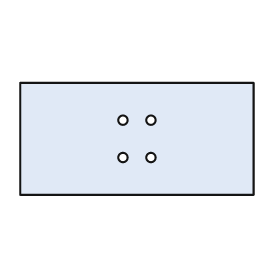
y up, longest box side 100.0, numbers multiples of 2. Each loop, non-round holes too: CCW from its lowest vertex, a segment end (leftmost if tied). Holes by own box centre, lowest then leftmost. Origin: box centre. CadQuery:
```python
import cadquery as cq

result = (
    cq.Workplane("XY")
    .moveTo(-50.0, -24.0)
    .lineTo(50.0, -24.0)
    .lineTo(50.0, 24.0)
    .lineTo(-50.0, 24.0)
    .close()
    .moveTo(-6.0, -8.0)
    .circle(2.0)
    .moveTo(6.0, -8.0)
    .circle(2.0)
    .moveTo(-6.0, 8.0)
    .circle(2.0)
    .moveTo(6.0, 8.0)
    .circle(2.0)
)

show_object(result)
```